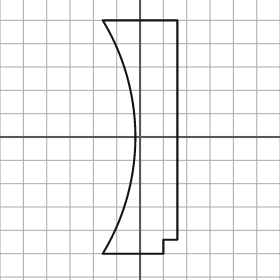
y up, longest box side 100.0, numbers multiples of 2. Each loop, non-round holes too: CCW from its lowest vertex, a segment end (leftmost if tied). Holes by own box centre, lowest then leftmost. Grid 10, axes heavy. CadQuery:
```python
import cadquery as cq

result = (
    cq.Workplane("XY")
    .moveTo(-16.0, -50.0)
    .lineTo(10.0, -50.0)
    .lineTo(10.0, -44.0)
    .lineTo(16.0, -44.0)
    .lineTo(16.0, 50.0)
    .lineTo(-16.0, 50.0)
    .threePointArc((-2.0, 0.0), (-16.0, -50.0))
    .close()
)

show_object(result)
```